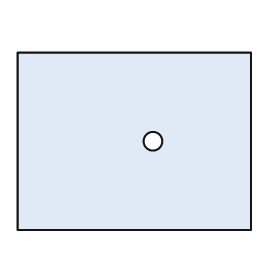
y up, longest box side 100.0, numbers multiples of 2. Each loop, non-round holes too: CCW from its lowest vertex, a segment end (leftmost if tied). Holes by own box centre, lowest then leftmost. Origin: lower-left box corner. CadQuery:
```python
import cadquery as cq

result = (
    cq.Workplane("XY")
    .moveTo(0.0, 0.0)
    .lineTo(100.0, 0.0)
    .lineTo(100.0, 76.0)
    .lineTo(0.0, 76.0)
    .close()
    .moveTo(58.0, 38.0)
    .circle(4.0)
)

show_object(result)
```